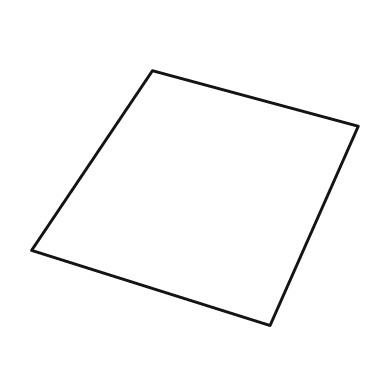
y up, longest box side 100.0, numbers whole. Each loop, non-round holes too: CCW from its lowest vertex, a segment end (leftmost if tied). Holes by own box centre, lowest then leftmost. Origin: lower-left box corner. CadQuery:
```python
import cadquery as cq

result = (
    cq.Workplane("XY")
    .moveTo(73.0, 0.0)
    .lineTo(100.0, 61.0)
    .lineTo(37.0, 78.0)
    .lineTo(0.0, 23.0)
    .close()
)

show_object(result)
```